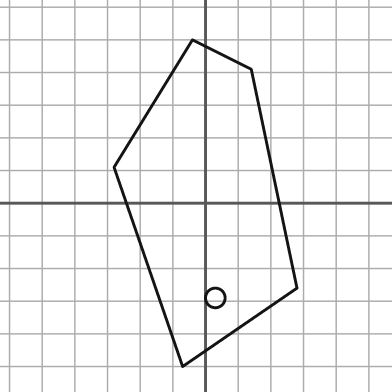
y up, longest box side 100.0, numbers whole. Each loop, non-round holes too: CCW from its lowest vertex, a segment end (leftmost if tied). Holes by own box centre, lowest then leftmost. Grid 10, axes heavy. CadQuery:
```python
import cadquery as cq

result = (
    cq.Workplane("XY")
    .moveTo(-7.0, -50.0)
    .lineTo(28.0, -26.0)
    .lineTo(14.0, 41.0)
    .lineTo(-4.0, 50.0)
    .lineTo(-28.0, 11.0)
    .close()
    .moveTo(3.0, -29.0)
    .circle(3.0)
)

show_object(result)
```